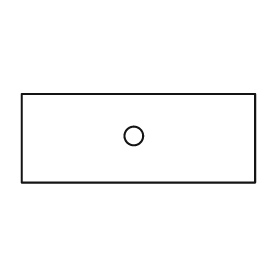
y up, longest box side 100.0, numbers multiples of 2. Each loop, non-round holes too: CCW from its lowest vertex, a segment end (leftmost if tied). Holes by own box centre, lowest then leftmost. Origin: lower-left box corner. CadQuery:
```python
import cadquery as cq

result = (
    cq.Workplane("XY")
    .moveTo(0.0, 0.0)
    .lineTo(100.0, 0.0)
    .lineTo(100.0, 38.0)
    .lineTo(0.0, 38.0)
    .close()
    .moveTo(48.0, 20.0)
    .circle(4.0)
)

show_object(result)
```